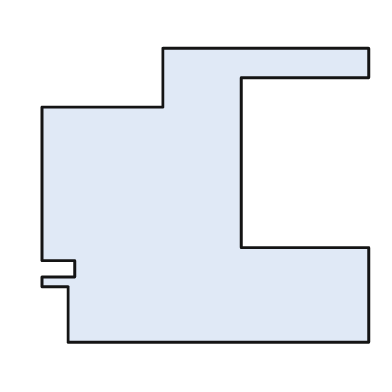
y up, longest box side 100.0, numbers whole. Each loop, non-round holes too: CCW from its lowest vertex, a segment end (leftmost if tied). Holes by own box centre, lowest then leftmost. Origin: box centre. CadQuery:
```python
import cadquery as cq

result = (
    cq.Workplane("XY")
    .moveTo(-42.0, -45.0)
    .lineTo(50.0, -45.0)
    .lineTo(50.0, -16.0)
    .lineTo(11.0, -16.0)
    .lineTo(11.0, 36.0)
    .lineTo(50.0, 36.0)
    .lineTo(50.0, 45.0)
    .lineTo(-13.0, 45.0)
    .lineTo(-13.0, 27.0)
    .lineTo(-50.0, 27.0)
    .lineTo(-50.0, -20.0)
    .lineTo(-40.0, -20.0)
    .lineTo(-40.0, -25.0)
    .lineTo(-50.0, -25.0)
    .lineTo(-50.0, -28.0)
    .lineTo(-42.0, -28.0)
    .close()
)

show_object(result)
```